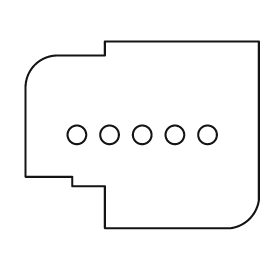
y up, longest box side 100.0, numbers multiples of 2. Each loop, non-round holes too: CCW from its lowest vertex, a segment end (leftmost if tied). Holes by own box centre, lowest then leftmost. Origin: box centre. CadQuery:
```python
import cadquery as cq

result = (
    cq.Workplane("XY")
    .moveTo(-16.0, -40.0)
    .lineTo(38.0, -40.0)
    .threePointArc((46.0, -36.0), (50.0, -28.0))
    .lineTo(50.0, 40.0)
    .lineTo(-16.0, 40.0)
    .lineTo(-16.0, 34.0)
    .lineTo(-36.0, 34.0)
    .threePointArc((-46.0, 30.0), (-50.0, 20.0))
    .lineTo(-50.0, -18.0)
    .lineTo(-30.0, -18.0)
    .lineTo(-30.0, -22.0)
    .lineTo(-16.0, -22.0)
    .close()
    .moveTo(-28.0, 0.0)
    .circle(4.0)
    .moveTo(-14.0, 0.0)
    .circle(4.0)
    .moveTo(0.0, 0.0)
    .circle(4.0)
    .moveTo(14.0, 0.0)
    .circle(4.0)
    .moveTo(28.0, 0.0)
    .circle(4.0)
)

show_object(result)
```